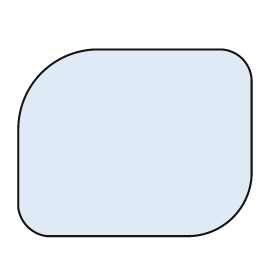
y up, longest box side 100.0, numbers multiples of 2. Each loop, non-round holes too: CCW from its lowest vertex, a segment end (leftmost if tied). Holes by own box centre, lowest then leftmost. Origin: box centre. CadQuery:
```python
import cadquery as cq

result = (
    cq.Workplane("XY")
    .moveTo(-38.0, -40.0)
    .lineTo(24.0, -40.0)
    .threePointArc((42.0, -32.0), (50.0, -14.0))
    .lineTo(50.0, 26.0)
    .threePointArc((46.0, 36.0), (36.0, 40.0))
    .lineTo(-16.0, 40.0)
    .threePointArc((-40.0, 30.0), (-50.0, 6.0))
    .lineTo(-50.0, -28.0)
    .threePointArc((-46.0, -36.0), (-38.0, -40.0))
    .close()
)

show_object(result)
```